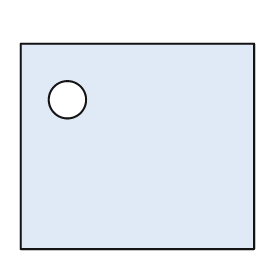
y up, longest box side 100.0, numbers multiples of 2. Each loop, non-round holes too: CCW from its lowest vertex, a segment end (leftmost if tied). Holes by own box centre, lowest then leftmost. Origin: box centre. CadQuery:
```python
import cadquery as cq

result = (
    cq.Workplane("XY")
    .moveTo(-50.0, -44.0)
    .lineTo(50.0, -44.0)
    .lineTo(50.0, 44.0)
    .lineTo(-50.0, 44.0)
    .close()
    .moveTo(-30.0, 20.0)
    .circle(8.0)
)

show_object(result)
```